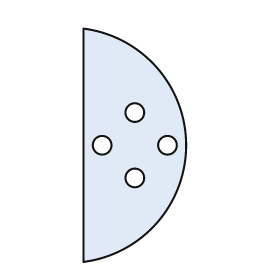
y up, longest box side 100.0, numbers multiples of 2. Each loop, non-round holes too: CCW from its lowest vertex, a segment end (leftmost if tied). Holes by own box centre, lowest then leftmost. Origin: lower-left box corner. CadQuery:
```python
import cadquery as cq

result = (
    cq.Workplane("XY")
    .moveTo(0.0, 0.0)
    .threePointArc((44.0, 50.0), (0.0, 100.0))
    .close()
    .moveTo(22.0, 36.0)
    .circle(4.0)
    .moveTo(8.0, 50.0)
    .circle(4.0)
    .moveTo(36.0, 50.0)
    .circle(4.0)
    .moveTo(22.0, 64.0)
    .circle(4.0)
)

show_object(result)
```